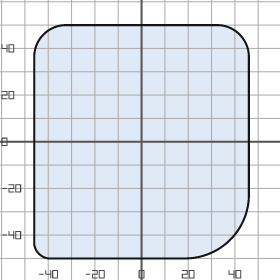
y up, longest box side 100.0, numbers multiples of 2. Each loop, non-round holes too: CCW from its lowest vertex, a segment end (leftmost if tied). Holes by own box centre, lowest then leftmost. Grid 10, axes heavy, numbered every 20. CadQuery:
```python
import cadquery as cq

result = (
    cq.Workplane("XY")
    .moveTo(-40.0, -50.0)
    .lineTo(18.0, -50.0)
    .threePointArc((38.0, -42.0), (46.0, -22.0))
    .lineTo(46.0, 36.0)
    .threePointArc((42.0, 46.0), (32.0, 50.0))
    .lineTo(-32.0, 50.0)
    .threePointArc((-42.0, 46.0), (-46.0, 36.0))
    .lineTo(-46.0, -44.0)
    .threePointArc((-44.0, -48.0), (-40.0, -50.0))
    .close()
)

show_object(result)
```